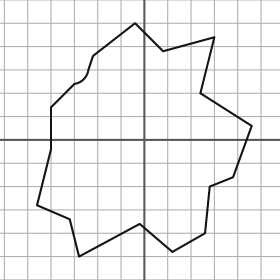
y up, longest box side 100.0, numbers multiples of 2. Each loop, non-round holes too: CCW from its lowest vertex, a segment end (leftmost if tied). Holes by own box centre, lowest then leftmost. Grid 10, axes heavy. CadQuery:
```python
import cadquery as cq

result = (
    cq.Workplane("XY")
    .moveTo(-28.0, -50.0)
    .lineTo(-2.0, -36.0)
    .lineTo(12.0, -48.0)
    .lineTo(26.0, -40.0)
    .lineTo(28.0, -20.0)
    .lineTo(38.0, -16.0)
    .lineTo(46.0, 6.0)
    .lineTo(24.0, 20.0)
    .lineTo(30.0, 44.0)
    .lineTo(8.0, 38.0)
    .lineTo(-4.0, 50.0)
    .lineTo(-22.0, 36.0)
    .lineTo(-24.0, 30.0)
    .threePointArc((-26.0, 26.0), (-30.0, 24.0))
    .lineTo(-40.0, 14.0)
    .lineTo(-40.0, -4.0)
    .lineTo(-46.0, -28.0)
    .lineTo(-32.0, -34.0)
    .close()
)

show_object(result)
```